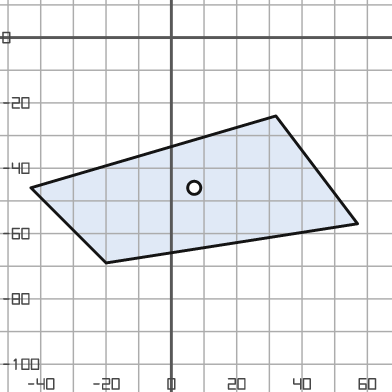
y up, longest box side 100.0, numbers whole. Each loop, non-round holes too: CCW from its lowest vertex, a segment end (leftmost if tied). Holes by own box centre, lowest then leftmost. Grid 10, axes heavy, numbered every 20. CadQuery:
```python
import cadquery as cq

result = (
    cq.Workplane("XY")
    .moveTo(-20.0, -69.0)
    .lineTo(57.0, -57.0)
    .lineTo(32.0, -24.0)
    .lineTo(-43.0, -46.0)
    .close()
    .moveTo(7.0, -46.0)
    .circle(2.0)
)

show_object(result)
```